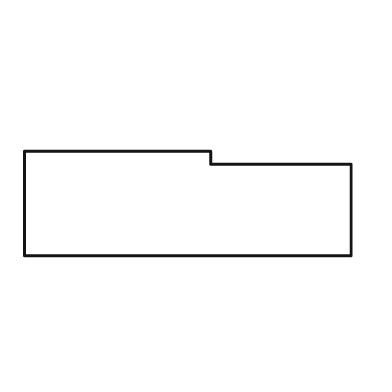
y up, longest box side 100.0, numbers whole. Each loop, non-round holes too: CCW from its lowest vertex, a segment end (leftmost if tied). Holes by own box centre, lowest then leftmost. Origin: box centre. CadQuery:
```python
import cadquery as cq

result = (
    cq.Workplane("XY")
    .moveTo(-50.0, -16.0)
    .lineTo(50.0, -16.0)
    .lineTo(50.0, 12.0)
    .lineTo(7.0, 12.0)
    .lineTo(7.0, 16.0)
    .lineTo(-50.0, 16.0)
    .close()
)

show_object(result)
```